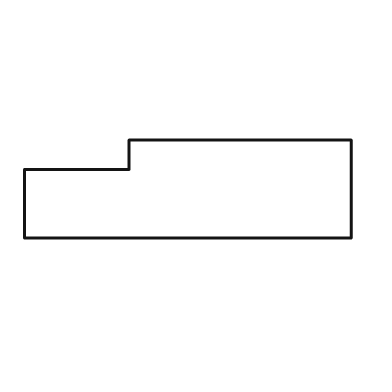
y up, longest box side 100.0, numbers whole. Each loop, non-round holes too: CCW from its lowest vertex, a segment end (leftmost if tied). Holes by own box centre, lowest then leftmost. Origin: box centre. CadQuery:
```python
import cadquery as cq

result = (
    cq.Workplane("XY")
    .moveTo(-50.0, -15.0)
    .lineTo(50.0, -15.0)
    .lineTo(50.0, 15.0)
    .lineTo(-18.0, 15.0)
    .lineTo(-18.0, 6.0)
    .lineTo(-50.0, 6.0)
    .close()
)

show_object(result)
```